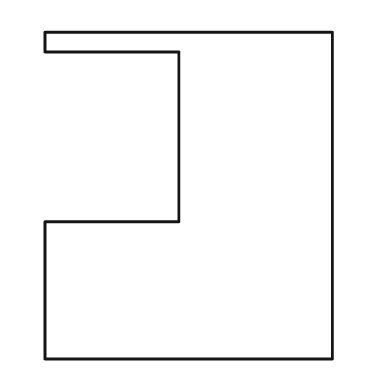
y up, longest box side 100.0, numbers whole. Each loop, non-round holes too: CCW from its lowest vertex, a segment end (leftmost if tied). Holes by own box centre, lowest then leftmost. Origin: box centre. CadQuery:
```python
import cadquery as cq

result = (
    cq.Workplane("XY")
    .moveTo(-44.0, -50.0)
    .lineTo(44.0, -50.0)
    .lineTo(44.0, 50.0)
    .lineTo(-44.0, 50.0)
    .lineTo(-44.0, 44.0)
    .lineTo(-3.0, 44.0)
    .lineTo(-3.0, -8.0)
    .lineTo(-44.0, -8.0)
    .close()
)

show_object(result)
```